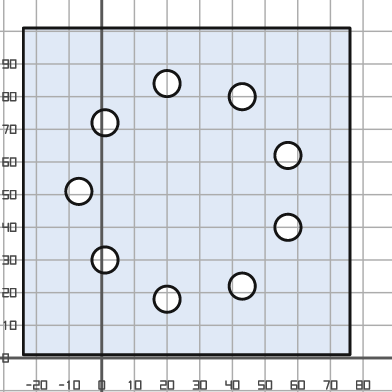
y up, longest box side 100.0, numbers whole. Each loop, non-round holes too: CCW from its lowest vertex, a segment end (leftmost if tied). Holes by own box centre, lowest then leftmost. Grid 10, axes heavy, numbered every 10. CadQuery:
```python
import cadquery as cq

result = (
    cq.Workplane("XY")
    .moveTo(-24.0, 1.0)
    .lineTo(76.0, 1.0)
    .lineTo(76.0, 101.0)
    .lineTo(-24.0, 101.0)
    .close()
    .moveTo(20.0, 18.0)
    .circle(4.0)
    .moveTo(43.0, 22.0)
    .circle(4.0)
    .moveTo(1.0, 30.0)
    .circle(4.0)
    .moveTo(57.0, 40.0)
    .circle(4.0)
    .moveTo(-7.0, 51.0)
    .circle(4.0)
    .moveTo(57.0, 62.0)
    .circle(4.0)
    .moveTo(1.0, 72.0)
    .circle(4.0)
    .moveTo(43.0, 80.0)
    .circle(4.0)
    .moveTo(20.0, 84.0)
    .circle(4.0)
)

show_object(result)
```